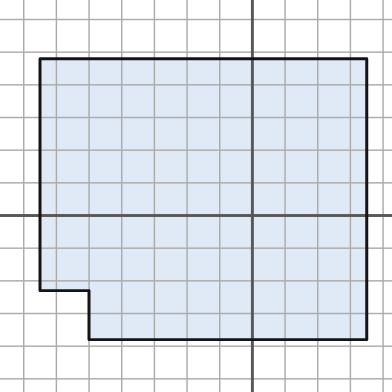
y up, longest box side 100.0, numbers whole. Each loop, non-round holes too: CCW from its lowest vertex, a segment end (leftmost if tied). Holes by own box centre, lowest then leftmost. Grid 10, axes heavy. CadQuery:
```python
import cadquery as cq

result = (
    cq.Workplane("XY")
    .moveTo(-50.0, -38.0)
    .lineTo(35.0, -38.0)
    .lineTo(35.0, 48.0)
    .lineTo(-65.0, 48.0)
    .lineTo(-65.0, -23.0)
    .lineTo(-50.0, -23.0)
    .close()
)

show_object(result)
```